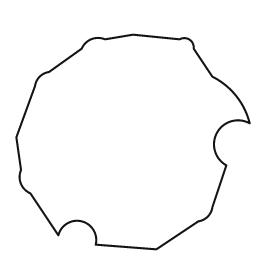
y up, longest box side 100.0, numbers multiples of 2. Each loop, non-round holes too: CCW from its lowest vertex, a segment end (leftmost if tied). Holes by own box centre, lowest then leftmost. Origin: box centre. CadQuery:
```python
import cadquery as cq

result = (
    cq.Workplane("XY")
    .moveTo(10.0, -46.0)
    .lineTo(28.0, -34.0)
    .threePointArc((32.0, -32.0), (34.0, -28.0))
    .lineTo(40.0, -10.0)
    .threePointArc((36.0, 4.0), (50.0, 8.0))
    .threePointArc((44.0, 20.0), (34.0, 28.0))
    .lineTo(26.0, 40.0)
    .threePointArc((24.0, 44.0), (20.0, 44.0))
    .lineTo(0.0, 46.0)
    .lineTo(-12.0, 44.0)
    .threePointArc((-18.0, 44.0), (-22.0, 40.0))
    .lineTo(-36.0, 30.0)
    .threePointArc((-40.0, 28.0), (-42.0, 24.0))
    .lineTo(-50.0, 2.0)
    .lineTo(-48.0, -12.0)
    .threePointArc((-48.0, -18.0), (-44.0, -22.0))
    .lineTo(-32.0, -40.0)
    .threePointArc((-22.0, -34.0), (-16.0, -44.0))
    .close()
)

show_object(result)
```